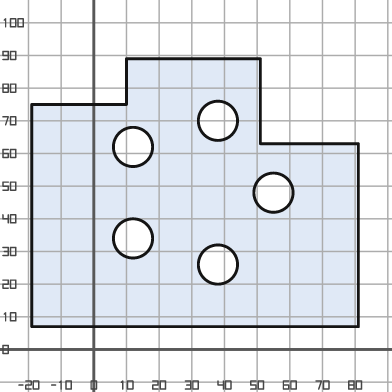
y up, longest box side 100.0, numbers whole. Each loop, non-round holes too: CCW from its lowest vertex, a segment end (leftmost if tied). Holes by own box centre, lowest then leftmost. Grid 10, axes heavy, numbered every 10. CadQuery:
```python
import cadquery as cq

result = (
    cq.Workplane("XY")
    .moveTo(-19.0, 7.0)
    .lineTo(81.0, 7.0)
    .lineTo(81.0, 63.0)
    .lineTo(51.0, 63.0)
    .lineTo(51.0, 89.0)
    .lineTo(10.0, 89.0)
    .lineTo(10.0, 75.0)
    .lineTo(-19.0, 75.0)
    .close()
    .moveTo(38.0, 26.0)
    .circle(6.0)
    .moveTo(12.0, 34.0)
    .circle(6.0)
    .moveTo(55.0, 48.0)
    .circle(6.0)
    .moveTo(12.0, 62.0)
    .circle(6.0)
    .moveTo(38.0, 70.0)
    .circle(6.0)
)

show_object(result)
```